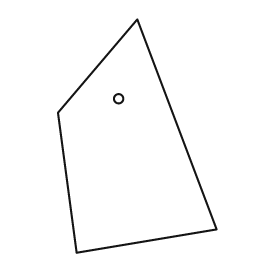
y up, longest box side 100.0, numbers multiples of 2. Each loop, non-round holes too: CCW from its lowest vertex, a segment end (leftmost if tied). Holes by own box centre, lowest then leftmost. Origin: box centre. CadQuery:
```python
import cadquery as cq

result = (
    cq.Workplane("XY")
    .moveTo(-26.0, -50.0)
    .lineTo(34.0, -40.0)
    .lineTo(0.0, 50.0)
    .lineTo(-34.0, 10.0)
    .close()
    .moveTo(-8.0, 16.0)
    .circle(2.0)
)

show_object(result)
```